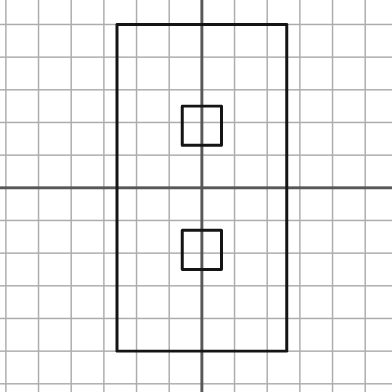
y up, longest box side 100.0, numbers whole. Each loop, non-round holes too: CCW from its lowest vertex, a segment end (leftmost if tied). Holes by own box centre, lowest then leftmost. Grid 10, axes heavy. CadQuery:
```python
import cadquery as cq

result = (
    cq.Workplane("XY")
    .moveTo(-26.0, -50.0)
    .lineTo(26.0, -50.0)
    .lineTo(26.0, 50.0)
    .lineTo(-26.0, 50.0)
    .close()
    .moveTo(-6.0, -25.0)
    .lineTo(6.0, -25.0)
    .lineTo(6.0, -13.0)
    .lineTo(-6.0, -13.0)
    .close()
    .moveTo(-6.0, 13.0)
    .lineTo(6.0, 13.0)
    .lineTo(6.0, 25.0)
    .lineTo(-6.0, 25.0)
    .close()
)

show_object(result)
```